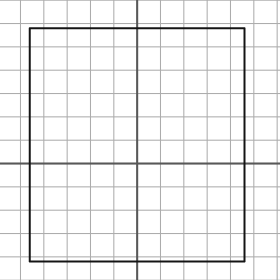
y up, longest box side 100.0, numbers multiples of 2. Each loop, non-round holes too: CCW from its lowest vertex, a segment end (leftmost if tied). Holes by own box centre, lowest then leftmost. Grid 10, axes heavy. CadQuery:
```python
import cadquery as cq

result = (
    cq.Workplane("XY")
    .moveTo(-46.0, -42.0)
    .lineTo(46.0, -42.0)
    .lineTo(46.0, 58.0)
    .lineTo(-46.0, 58.0)
    .close()
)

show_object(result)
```